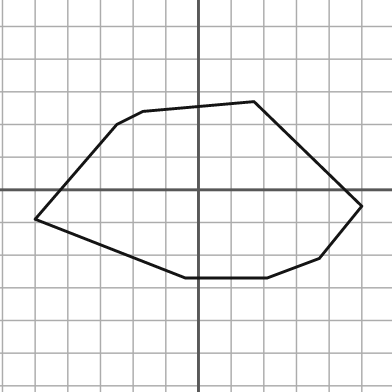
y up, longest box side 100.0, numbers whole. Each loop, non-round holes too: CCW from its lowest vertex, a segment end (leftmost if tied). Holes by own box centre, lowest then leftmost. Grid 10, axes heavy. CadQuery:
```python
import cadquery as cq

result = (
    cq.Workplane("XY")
    .moveTo(-4.0, -27.0)
    .lineTo(21.0, -27.0)
    .lineTo(37.0, -21.0)
    .lineTo(50.0, -5.0)
    .lineTo(17.0, 27.0)
    .lineTo(-17.0, 24.0)
    .lineTo(-25.0, 20.0)
    .lineTo(-50.0, -9.0)
    .close()
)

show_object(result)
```